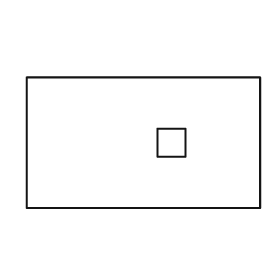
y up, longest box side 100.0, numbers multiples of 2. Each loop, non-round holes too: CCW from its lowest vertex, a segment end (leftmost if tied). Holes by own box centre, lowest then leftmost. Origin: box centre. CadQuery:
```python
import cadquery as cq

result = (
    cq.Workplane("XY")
    .moveTo(-50.0, -28.0)
    .lineTo(50.0, -28.0)
    .lineTo(50.0, 28.0)
    .lineTo(-50.0, 28.0)
    .close()
    .moveTo(6.0, -6.0)
    .lineTo(18.0, -6.0)
    .lineTo(18.0, 6.0)
    .lineTo(6.0, 6.0)
    .close()
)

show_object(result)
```